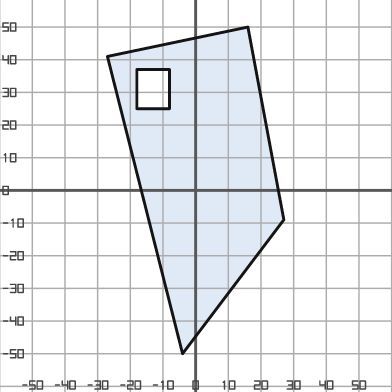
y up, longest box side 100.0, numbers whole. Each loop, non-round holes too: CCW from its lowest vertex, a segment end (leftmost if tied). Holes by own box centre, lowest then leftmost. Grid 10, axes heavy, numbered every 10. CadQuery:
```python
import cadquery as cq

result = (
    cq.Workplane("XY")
    .moveTo(-4.0, -50.0)
    .lineTo(27.0, -9.0)
    .lineTo(16.0, 50.0)
    .lineTo(-27.0, 41.0)
    .close()
    .moveTo(-18.0, 25.0)
    .lineTo(-8.0, 25.0)
    .lineTo(-8.0, 37.0)
    .lineTo(-18.0, 37.0)
    .close()
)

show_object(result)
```